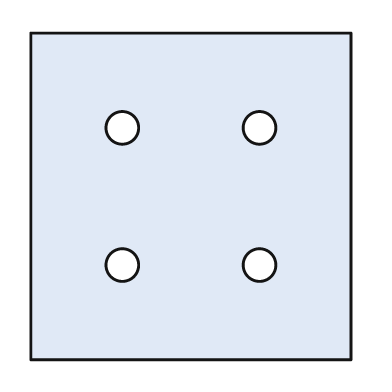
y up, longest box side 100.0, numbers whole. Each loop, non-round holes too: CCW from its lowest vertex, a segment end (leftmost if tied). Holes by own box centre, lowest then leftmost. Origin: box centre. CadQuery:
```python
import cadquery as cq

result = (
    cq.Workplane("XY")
    .moveTo(-49.0, -50.0)
    .lineTo(49.0, -50.0)
    .lineTo(49.0, 50.0)
    .lineTo(-49.0, 50.0)
    .close()
    .moveTo(-21.0, -21.0)
    .circle(5.0)
    .moveTo(21.0, -21.0)
    .circle(5.0)
    .moveTo(-21.0, 21.0)
    .circle(5.0)
    .moveTo(21.0, 21.0)
    .circle(5.0)
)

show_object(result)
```